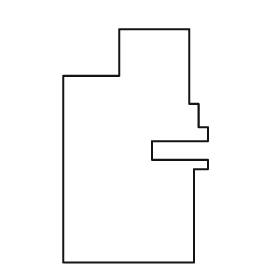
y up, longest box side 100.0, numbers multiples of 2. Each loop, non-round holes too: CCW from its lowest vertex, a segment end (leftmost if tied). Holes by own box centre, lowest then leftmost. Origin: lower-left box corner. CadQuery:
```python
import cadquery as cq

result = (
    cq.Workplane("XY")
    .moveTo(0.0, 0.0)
    .lineTo(56.0, 0.0)
    .lineTo(56.0, 40.0)
    .lineTo(62.0, 40.0)
    .lineTo(62.0, 44.0)
    .lineTo(38.0, 44.0)
    .lineTo(38.0, 52.0)
    .lineTo(62.0, 52.0)
    .lineTo(62.0, 58.0)
    .lineTo(58.0, 58.0)
    .lineTo(58.0, 68.0)
    .lineTo(54.0, 68.0)
    .lineTo(54.0, 100.0)
    .lineTo(24.0, 100.0)
    .lineTo(24.0, 80.0)
    .lineTo(0.0, 80.0)
    .close()
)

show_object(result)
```